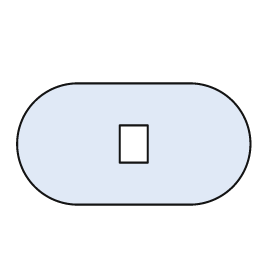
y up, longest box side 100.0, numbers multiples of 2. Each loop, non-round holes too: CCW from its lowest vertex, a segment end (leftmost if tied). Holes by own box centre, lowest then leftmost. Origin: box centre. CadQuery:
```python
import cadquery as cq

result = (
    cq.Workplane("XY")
    .moveTo(-24.0, -26.0)
    .lineTo(24.0, -26.0)
    .threePointArc((50.0, 0.0), (24.0, 26.0))
    .lineTo(-24.0, 26.0)
    .threePointArc((-50.0, 0.0), (-24.0, -26.0))
    .close()
    .moveTo(-6.0, -8.0)
    .lineTo(6.0, -8.0)
    .lineTo(6.0, 8.0)
    .lineTo(-6.0, 8.0)
    .close()
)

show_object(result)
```